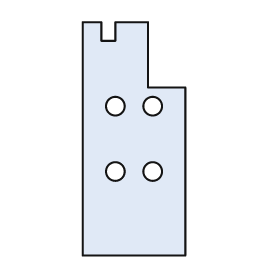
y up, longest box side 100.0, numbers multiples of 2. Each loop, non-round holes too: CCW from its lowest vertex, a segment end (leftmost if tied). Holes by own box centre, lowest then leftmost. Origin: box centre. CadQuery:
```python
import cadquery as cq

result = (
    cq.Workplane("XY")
    .moveTo(-22.0, -50.0)
    .lineTo(22.0, -50.0)
    .lineTo(22.0, 22.0)
    .lineTo(6.0, 22.0)
    .lineTo(6.0, 50.0)
    .lineTo(-8.0, 50.0)
    .lineTo(-8.0, 42.0)
    .lineTo(-14.0, 42.0)
    .lineTo(-14.0, 50.0)
    .lineTo(-22.0, 50.0)
    .close()
    .moveTo(-8.0, -14.0)
    .circle(4.0)
    .moveTo(8.0, -14.0)
    .circle(4.0)
    .moveTo(-8.0, 14.0)
    .circle(4.0)
    .moveTo(8.0, 14.0)
    .circle(4.0)
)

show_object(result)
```